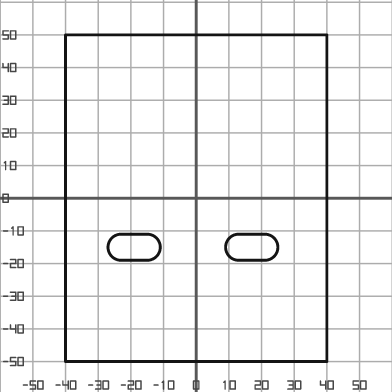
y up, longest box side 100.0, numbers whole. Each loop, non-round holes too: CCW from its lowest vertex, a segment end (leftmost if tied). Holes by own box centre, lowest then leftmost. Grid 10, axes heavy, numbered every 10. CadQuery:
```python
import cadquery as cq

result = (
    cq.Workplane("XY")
    .moveTo(-40.0, -50.0)
    .lineTo(40.0, -50.0)
    .lineTo(40.0, 50.0)
    .lineTo(-40.0, 50.0)
    .close()
    .moveTo(-23.0, -19.0)
    .lineTo(-15.0, -19.0)
    .threePointArc((-11.0, -15.0), (-15.0, -11.0))
    .lineTo(-23.0, -11.0)
    .threePointArc((-27.0, -15.0), (-23.0, -19.0))
    .close()
    .moveTo(13.0, -19.0)
    .lineTo(21.0, -19.0)
    .threePointArc((25.0, -15.0), (21.0, -11.0))
    .lineTo(13.0, -11.0)
    .threePointArc((9.0, -15.0), (13.0, -19.0))
    .close()
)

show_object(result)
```